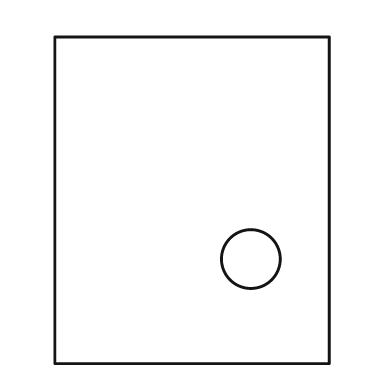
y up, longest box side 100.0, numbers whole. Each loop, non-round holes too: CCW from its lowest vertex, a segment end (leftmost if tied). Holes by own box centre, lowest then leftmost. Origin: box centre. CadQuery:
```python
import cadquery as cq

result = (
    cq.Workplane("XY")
    .moveTo(-42.0, -50.0)
    .lineTo(42.0, -50.0)
    .lineTo(42.0, 50.0)
    .lineTo(-42.0, 50.0)
    .close()
    .moveTo(18.0, -18.0)
    .circle(9.0)
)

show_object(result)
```